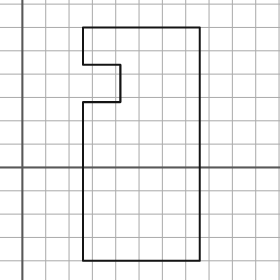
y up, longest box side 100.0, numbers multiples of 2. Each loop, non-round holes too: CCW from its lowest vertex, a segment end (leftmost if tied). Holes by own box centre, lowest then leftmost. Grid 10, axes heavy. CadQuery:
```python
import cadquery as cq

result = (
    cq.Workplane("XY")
    .moveTo(26.0, -40.0)
    .lineTo(76.0, -40.0)
    .lineTo(76.0, 60.0)
    .lineTo(26.0, 60.0)
    .lineTo(26.0, 44.0)
    .lineTo(42.0, 44.0)
    .lineTo(42.0, 28.0)
    .lineTo(26.0, 28.0)
    .close()
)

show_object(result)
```